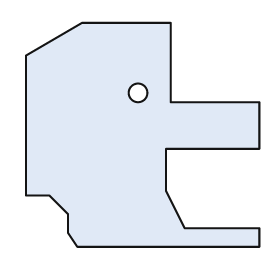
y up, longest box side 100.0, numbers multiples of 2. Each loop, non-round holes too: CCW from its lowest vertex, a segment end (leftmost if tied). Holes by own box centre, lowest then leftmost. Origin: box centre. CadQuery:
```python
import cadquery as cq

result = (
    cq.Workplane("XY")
    .moveTo(-28.0, -48.0)
    .lineTo(50.0, -48.0)
    .lineTo(50.0, -40.0)
    .lineTo(18.0, -40.0)
    .lineTo(10.0, -24.0)
    .lineTo(10.0, -6.0)
    .lineTo(50.0, -6.0)
    .lineTo(50.0, 14.0)
    .lineTo(12.0, 14.0)
    .lineTo(12.0, 48.0)
    .lineTo(-26.0, 48.0)
    .lineTo(-50.0, 34.0)
    .lineTo(-50.0, -26.0)
    .lineTo(-40.0, -26.0)
    .lineTo(-32.0, -34.0)
    .lineTo(-32.0, -42.0)
    .close()
    .moveTo(-2.0, 18.0)
    .circle(4.0)
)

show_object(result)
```